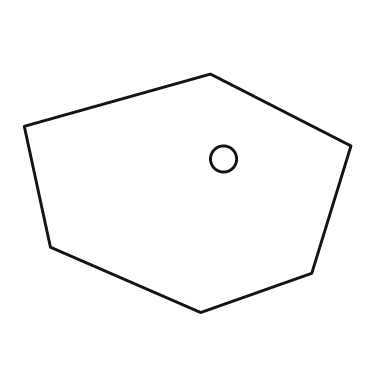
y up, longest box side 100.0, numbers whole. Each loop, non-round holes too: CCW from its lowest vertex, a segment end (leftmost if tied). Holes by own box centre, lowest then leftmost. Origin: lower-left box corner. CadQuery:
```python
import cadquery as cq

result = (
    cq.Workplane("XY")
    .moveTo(54.0, 0.0)
    .lineTo(88.0, 12.0)
    .lineTo(100.0, 51.0)
    .lineTo(57.0, 73.0)
    .lineTo(0.0, 57.0)
    .lineTo(8.0, 20.0)
    .close()
    .moveTo(61.0, 47.0)
    .circle(4.0)
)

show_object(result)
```